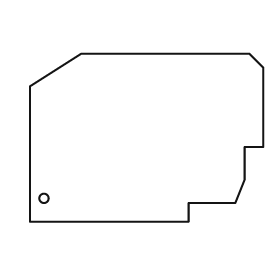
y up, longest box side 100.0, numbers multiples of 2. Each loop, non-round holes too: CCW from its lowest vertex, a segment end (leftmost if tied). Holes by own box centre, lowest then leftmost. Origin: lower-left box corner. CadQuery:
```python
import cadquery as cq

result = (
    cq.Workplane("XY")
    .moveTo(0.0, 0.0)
    .lineTo(68.0, 0.0)
    .lineTo(68.0, 8.0)
    .lineTo(88.0, 8.0)
    .lineTo(92.0, 18.0)
    .lineTo(92.0, 32.0)
    .lineTo(100.0, 32.0)
    .lineTo(100.0, 66.0)
    .lineTo(94.0, 72.0)
    .lineTo(22.0, 72.0)
    .lineTo(0.0, 58.0)
    .close()
    .moveTo(6.0, 10.0)
    .circle(2.0)
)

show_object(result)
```